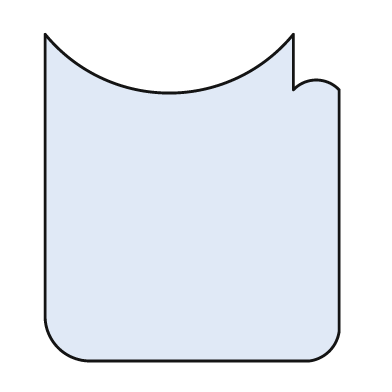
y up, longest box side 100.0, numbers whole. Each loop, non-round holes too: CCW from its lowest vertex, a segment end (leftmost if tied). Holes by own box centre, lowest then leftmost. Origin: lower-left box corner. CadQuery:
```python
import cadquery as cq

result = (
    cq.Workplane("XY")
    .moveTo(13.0, 0.0)
    .lineTo(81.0, 0.0)
    .threePointArc((87.0, 3.0), (90.0, 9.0))
    .lineTo(90.0, 83.0)
    .threePointArc((83.0, 86.0), (76.0, 83.0))
    .lineTo(76.0, 100.0)
    .threePointArc((38.0, 82.0), (0.0, 100.0))
    .lineTo(0.0, 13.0)
    .threePointArc((4.0, 4.0), (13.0, 0.0))
    .close()
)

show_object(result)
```